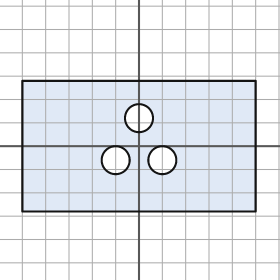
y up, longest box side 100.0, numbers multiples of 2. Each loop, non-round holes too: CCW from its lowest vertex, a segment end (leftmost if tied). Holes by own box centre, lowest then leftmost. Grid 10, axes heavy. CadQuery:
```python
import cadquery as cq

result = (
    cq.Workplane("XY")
    .moveTo(-50.0, -28.0)
    .lineTo(50.0, -28.0)
    .lineTo(50.0, 28.0)
    .lineTo(-50.0, 28.0)
    .close()
    .moveTo(-10.0, -6.0)
    .circle(6.0)
    .moveTo(10.0, -6.0)
    .circle(6.0)
    .moveTo(0.0, 12.0)
    .circle(6.0)
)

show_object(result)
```